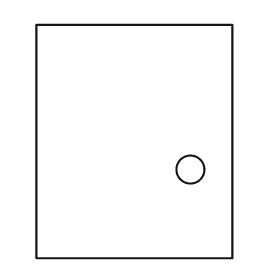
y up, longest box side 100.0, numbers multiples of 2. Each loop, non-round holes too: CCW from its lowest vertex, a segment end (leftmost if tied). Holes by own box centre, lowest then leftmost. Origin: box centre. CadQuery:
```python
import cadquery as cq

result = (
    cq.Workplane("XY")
    .moveTo(-42.0, -50.0)
    .lineTo(42.0, -50.0)
    .lineTo(42.0, 50.0)
    .lineTo(-42.0, 50.0)
    .close()
    .moveTo(24.0, -12.0)
    .circle(6.0)
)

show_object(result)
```